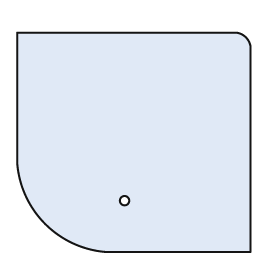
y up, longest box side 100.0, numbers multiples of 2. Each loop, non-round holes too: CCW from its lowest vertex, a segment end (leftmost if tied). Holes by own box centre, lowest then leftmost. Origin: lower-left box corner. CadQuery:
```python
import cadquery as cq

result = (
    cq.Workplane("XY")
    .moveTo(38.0, 0.0)
    .lineTo(100.0, 0.0)
    .lineTo(100.0, 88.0)
    .threePointArc((98.0, 92.0), (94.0, 94.0))
    .lineTo(0.0, 94.0)
    .lineTo(0.0, 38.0)
    .threePointArc((12.0, 12.0), (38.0, 0.0))
    .close()
    .moveTo(46.0, 22.0)
    .circle(2.0)
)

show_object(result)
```